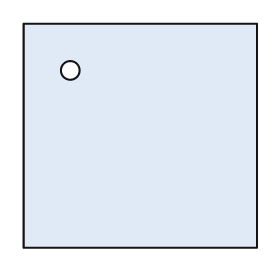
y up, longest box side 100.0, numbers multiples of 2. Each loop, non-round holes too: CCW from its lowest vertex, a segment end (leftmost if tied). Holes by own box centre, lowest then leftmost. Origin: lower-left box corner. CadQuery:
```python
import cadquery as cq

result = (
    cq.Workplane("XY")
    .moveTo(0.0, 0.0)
    .lineTo(100.0, 0.0)
    .lineTo(100.0, 96.0)
    .lineTo(0.0, 96.0)
    .close()
    .moveTo(20.0, 76.0)
    .circle(4.0)
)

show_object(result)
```